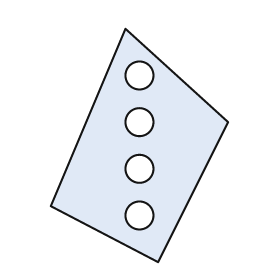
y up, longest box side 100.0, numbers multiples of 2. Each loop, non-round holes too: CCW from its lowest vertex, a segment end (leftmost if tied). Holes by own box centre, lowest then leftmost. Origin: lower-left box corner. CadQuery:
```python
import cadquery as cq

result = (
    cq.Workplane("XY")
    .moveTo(46.0, 0.0)
    .lineTo(76.0, 60.0)
    .lineTo(32.0, 100.0)
    .lineTo(0.0, 24.0)
    .close()
    .moveTo(38.0, 20.0)
    .circle(6.0)
    .moveTo(38.0, 40.0)
    .circle(6.0)
    .moveTo(38.0, 60.0)
    .circle(6.0)
    .moveTo(38.0, 80.0)
    .circle(6.0)
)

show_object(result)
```